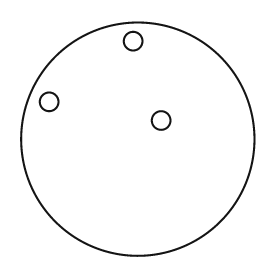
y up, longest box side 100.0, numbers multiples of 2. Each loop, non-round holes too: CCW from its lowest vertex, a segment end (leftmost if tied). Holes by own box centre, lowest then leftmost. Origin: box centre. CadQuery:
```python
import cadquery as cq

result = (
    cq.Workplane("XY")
    .moveTo(0.0, 0.0)
    .circle(50.0)
    .moveTo(10.0, 8.0)
    .circle(4.0)
    .moveTo(-38.0, 16.0)
    .circle(4.0)
    .moveTo(-2.0, 42.0)
    .circle(4.0)
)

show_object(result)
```